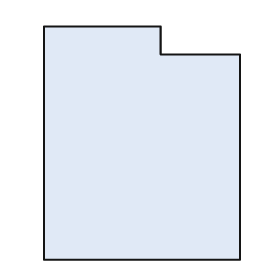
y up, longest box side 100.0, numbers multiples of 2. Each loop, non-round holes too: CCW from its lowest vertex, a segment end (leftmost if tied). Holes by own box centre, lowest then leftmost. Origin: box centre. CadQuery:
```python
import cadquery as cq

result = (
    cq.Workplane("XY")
    .moveTo(-42.0, -50.0)
    .lineTo(42.0, -50.0)
    .lineTo(42.0, 38.0)
    .lineTo(8.0, 38.0)
    .lineTo(8.0, 50.0)
    .lineTo(-42.0, 50.0)
    .close()
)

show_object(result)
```